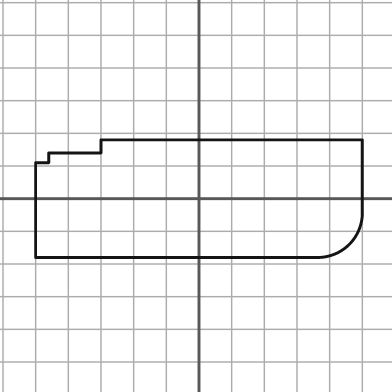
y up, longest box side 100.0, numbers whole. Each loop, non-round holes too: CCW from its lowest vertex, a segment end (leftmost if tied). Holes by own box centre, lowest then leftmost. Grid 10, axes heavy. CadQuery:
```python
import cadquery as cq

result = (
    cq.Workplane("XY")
    .moveTo(-50.0, -18.0)
    .lineTo(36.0, -18.0)
    .threePointArc((46.0, -14.0), (50.0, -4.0))
    .lineTo(50.0, 18.0)
    .lineTo(-30.0, 18.0)
    .lineTo(-30.0, 14.0)
    .lineTo(-46.0, 14.0)
    .lineTo(-46.0, 11.0)
    .lineTo(-50.0, 11.0)
    .close()
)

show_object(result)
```